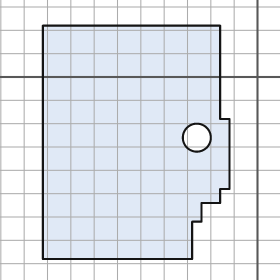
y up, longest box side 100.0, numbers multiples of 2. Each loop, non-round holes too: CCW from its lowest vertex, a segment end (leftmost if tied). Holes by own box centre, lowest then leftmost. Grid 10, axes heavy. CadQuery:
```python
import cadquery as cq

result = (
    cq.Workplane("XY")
    .moveTo(-92.0, -78.0)
    .lineTo(-28.0, -78.0)
    .lineTo(-28.0, -62.0)
    .lineTo(-24.0, -62.0)
    .lineTo(-24.0, -54.0)
    .lineTo(-16.0, -54.0)
    .lineTo(-16.0, -48.0)
    .lineTo(-12.0, -48.0)
    .lineTo(-12.0, -18.0)
    .lineTo(-16.0, -18.0)
    .lineTo(-16.0, 22.0)
    .lineTo(-92.0, 22.0)
    .close()
    .moveTo(-26.0, -26.0)
    .circle(6.0)
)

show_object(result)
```